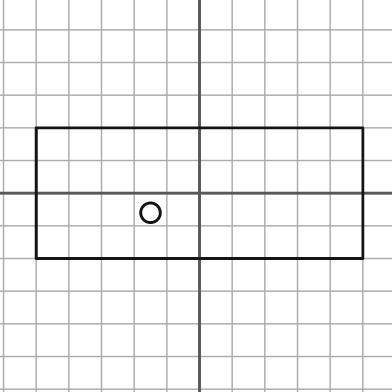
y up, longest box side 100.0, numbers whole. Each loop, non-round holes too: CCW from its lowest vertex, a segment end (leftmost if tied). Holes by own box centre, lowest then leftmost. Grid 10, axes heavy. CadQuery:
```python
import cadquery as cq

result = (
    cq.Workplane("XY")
    .moveTo(-50.0, -20.0)
    .lineTo(50.0, -20.0)
    .lineTo(50.0, 20.0)
    .lineTo(-50.0, 20.0)
    .close()
    .moveTo(-15.0, -6.0)
    .circle(3.0)
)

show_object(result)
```